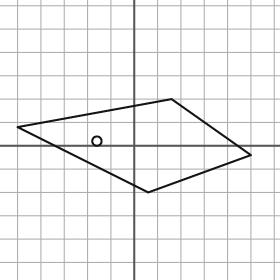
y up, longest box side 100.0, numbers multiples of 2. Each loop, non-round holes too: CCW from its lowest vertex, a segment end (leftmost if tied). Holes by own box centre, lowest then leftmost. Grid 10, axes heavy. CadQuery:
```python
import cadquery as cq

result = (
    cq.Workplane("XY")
    .moveTo(6.0, -20.0)
    .lineTo(50.0, -4.0)
    .lineTo(16.0, 20.0)
    .lineTo(-50.0, 8.0)
    .close()
    .moveTo(-16.0, 2.0)
    .circle(2.0)
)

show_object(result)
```